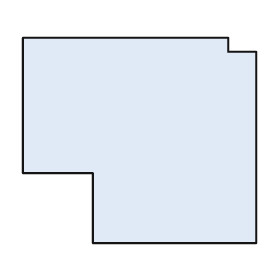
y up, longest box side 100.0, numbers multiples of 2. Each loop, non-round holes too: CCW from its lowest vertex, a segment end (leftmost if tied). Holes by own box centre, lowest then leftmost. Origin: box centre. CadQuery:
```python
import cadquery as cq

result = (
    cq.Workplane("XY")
    .moveTo(-20.0, -44.0)
    .lineTo(50.0, -44.0)
    .lineTo(50.0, 38.0)
    .lineTo(38.0, 38.0)
    .lineTo(38.0, 44.0)
    .lineTo(-50.0, 44.0)
    .lineTo(-50.0, -14.0)
    .lineTo(-20.0, -14.0)
    .close()
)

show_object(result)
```